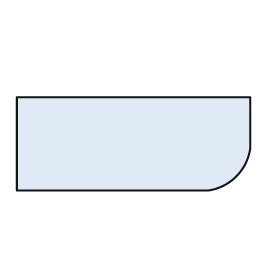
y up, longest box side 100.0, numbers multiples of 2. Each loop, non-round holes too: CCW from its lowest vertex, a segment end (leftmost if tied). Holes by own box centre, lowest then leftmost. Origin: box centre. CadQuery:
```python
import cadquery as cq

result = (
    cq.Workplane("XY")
    .moveTo(-50.0, -20.0)
    .lineTo(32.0, -20.0)
    .threePointArc((44.0, -14.0), (50.0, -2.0))
    .lineTo(50.0, 20.0)
    .lineTo(-50.0, 20.0)
    .close()
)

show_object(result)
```